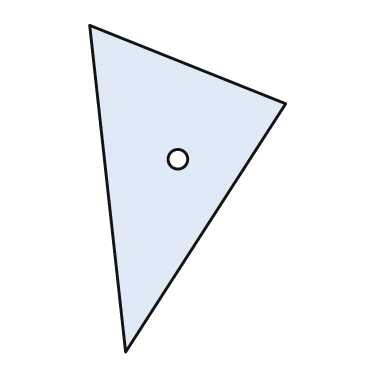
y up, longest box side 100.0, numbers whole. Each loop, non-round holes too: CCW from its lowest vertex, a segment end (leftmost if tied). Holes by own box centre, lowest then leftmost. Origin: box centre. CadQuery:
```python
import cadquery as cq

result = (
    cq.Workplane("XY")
    .moveTo(-19.0, -50.0)
    .lineTo(30.0, 26.0)
    .lineTo(-30.0, 50.0)
    .close()
    .moveTo(-3.0, 9.0)
    .circle(3.0)
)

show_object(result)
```